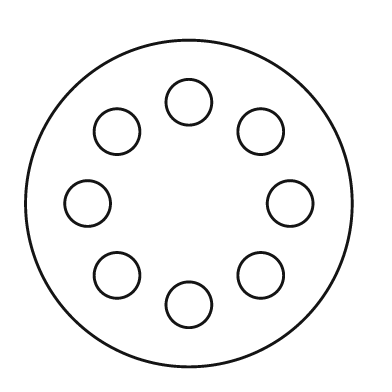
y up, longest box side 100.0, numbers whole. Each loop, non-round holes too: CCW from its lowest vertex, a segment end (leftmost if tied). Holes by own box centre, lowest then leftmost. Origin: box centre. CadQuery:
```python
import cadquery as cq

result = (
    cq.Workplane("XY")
    .moveTo(0.0, 0.0)
    .circle(50.0)
    .moveTo(0.0, -31.0)
    .circle(7.0)
    .moveTo(-22.0, -22.0)
    .circle(7.0)
    .moveTo(22.0, -22.0)
    .circle(7.0)
    .moveTo(-31.0, 0.0)
    .circle(7.0)
    .moveTo(31.0, 0.0)
    .circle(7.0)
    .moveTo(-22.0, 22.0)
    .circle(7.0)
    .moveTo(22.0, 22.0)
    .circle(7.0)
    .moveTo(0.0, 31.0)
    .circle(7.0)
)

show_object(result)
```